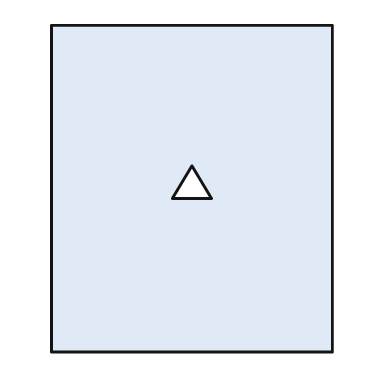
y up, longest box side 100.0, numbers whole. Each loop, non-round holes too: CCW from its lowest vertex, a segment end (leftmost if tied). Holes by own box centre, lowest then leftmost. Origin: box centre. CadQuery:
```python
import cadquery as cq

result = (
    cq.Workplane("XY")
    .moveTo(-43.0, -50.0)
    .lineTo(43.0, -50.0)
    .lineTo(43.0, 50.0)
    .lineTo(-43.0, 50.0)
    .close()
    .moveTo(-6.0, -3.0)
    .lineTo(6.0, -3.0)
    .lineTo(0.0, 7.0)
    .close()
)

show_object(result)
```